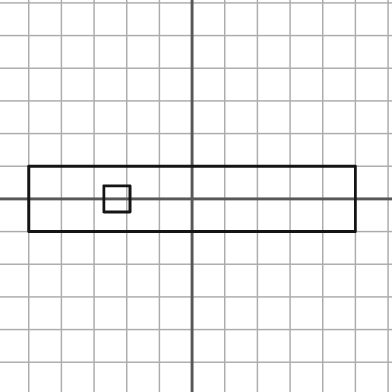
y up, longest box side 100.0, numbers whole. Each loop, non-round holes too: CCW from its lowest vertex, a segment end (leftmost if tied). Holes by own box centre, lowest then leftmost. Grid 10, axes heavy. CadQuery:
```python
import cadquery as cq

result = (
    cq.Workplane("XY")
    .moveTo(-50.0, -10.0)
    .lineTo(50.0, -10.0)
    .lineTo(50.0, 10.0)
    .lineTo(-50.0, 10.0)
    .close()
    .moveTo(-27.0, -4.0)
    .lineTo(-19.0, -4.0)
    .lineTo(-19.0, 4.0)
    .lineTo(-27.0, 4.0)
    .close()
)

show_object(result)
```